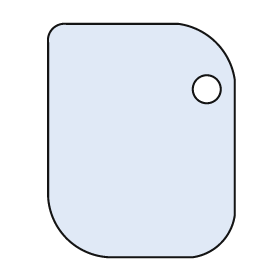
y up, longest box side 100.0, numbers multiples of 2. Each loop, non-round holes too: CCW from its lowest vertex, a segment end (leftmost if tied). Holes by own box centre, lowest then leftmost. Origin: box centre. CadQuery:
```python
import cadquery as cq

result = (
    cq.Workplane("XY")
    .moveTo(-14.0, -50.0)
    .lineTo(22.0, -50.0)
    .threePointArc((34.0, -44.0), (40.0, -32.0))
    .lineTo(40.0, 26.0)
    .threePointArc((32.0, 42.0), (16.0, 50.0))
    .lineTo(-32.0, 50.0)
    .threePointArc((-38.0, 48.0), (-40.0, 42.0))
    .lineTo(-40.0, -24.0)
    .threePointArc((-32.0, -42.0), (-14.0, -50.0))
    .close()
    .moveTo(28.0, 22.0)
    .circle(6.0)
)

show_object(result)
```